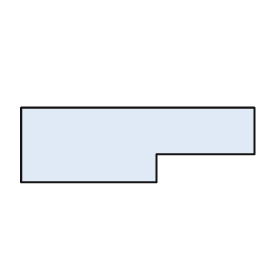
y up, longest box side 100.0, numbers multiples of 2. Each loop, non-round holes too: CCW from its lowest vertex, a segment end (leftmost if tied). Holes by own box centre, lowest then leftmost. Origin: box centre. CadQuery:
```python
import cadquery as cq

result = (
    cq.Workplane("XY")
    .moveTo(-50.0, -16.0)
    .lineTo(8.0, -16.0)
    .lineTo(8.0, -4.0)
    .lineTo(50.0, -4.0)
    .lineTo(50.0, 16.0)
    .lineTo(-50.0, 16.0)
    .close()
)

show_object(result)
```